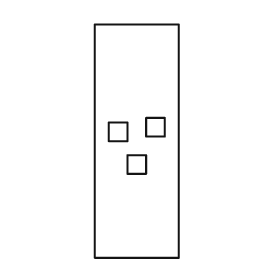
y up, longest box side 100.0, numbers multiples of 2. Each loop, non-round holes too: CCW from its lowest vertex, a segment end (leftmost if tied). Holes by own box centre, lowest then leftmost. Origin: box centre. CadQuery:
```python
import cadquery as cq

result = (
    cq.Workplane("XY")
    .moveTo(-18.0, -50.0)
    .lineTo(18.0, -50.0)
    .lineTo(18.0, 50.0)
    .lineTo(-18.0, 50.0)
    .close()
    .moveTo(-4.0, -14.0)
    .lineTo(4.0, -14.0)
    .lineTo(4.0, -6.0)
    .lineTo(-4.0, -6.0)
    .close()
    .moveTo(-12.0, 0.0)
    .lineTo(-4.0, 0.0)
    .lineTo(-4.0, 8.0)
    .lineTo(-12.0, 8.0)
    .close()
    .moveTo(4.0, 2.0)
    .lineTo(12.0, 2.0)
    .lineTo(12.0, 10.0)
    .lineTo(4.0, 10.0)
    .close()
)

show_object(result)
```